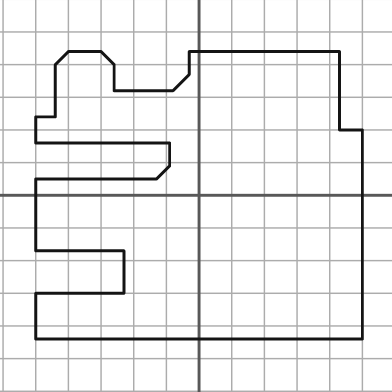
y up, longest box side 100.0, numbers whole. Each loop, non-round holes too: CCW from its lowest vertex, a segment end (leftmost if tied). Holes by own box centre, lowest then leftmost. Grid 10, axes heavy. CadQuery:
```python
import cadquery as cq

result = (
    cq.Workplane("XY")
    .moveTo(-50.0, -44.0)
    .lineTo(50.0, -44.0)
    .lineTo(50.0, 20.0)
    .lineTo(43.0, 20.0)
    .lineTo(43.0, 44.0)
    .lineTo(-3.0, 44.0)
    .lineTo(-3.0, 37.0)
    .lineTo(-8.0, 32.0)
    .lineTo(-26.0, 32.0)
    .lineTo(-26.0, 40.0)
    .lineTo(-30.0, 44.0)
    .lineTo(-40.0, 44.0)
    .lineTo(-44.0, 40.0)
    .lineTo(-44.0, 24.0)
    .lineTo(-50.0, 24.0)
    .lineTo(-50.0, 16.0)
    .lineTo(-9.0, 16.0)
    .lineTo(-9.0, 9.0)
    .lineTo(-13.0, 5.0)
    .lineTo(-50.0, 5.0)
    .lineTo(-50.0, -17.0)
    .lineTo(-23.0, -17.0)
    .lineTo(-23.0, -30.0)
    .lineTo(-50.0, -30.0)
    .close()
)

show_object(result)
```